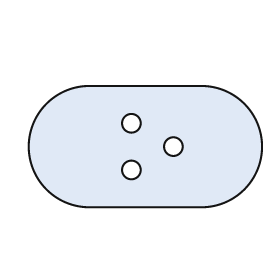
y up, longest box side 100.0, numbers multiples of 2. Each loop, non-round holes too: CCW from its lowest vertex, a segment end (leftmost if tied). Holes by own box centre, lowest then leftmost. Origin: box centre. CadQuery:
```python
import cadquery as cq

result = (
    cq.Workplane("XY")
    .moveTo(-24.0, -26.0)
    .lineTo(24.0, -26.0)
    .threePointArc((50.0, 0.0), (24.0, 26.0))
    .lineTo(-24.0, 26.0)
    .threePointArc((-50.0, 0.0), (-24.0, -26.0))
    .close()
    .moveTo(-6.0, -10.0)
    .circle(4.0)
    .moveTo(12.0, 0.0)
    .circle(4.0)
    .moveTo(-6.0, 10.0)
    .circle(4.0)
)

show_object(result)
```